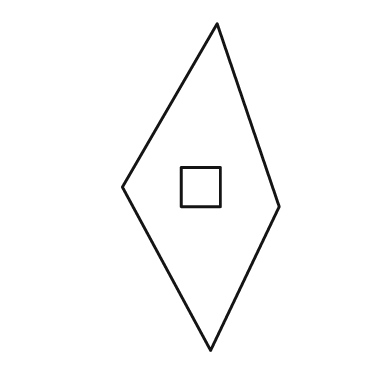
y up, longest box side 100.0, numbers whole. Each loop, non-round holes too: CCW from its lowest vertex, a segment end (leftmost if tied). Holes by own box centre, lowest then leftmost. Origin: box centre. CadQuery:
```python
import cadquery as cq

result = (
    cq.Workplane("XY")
    .moveTo(3.0, -50.0)
    .lineTo(24.0, -6.0)
    .lineTo(5.0, 50.0)
    .lineTo(-24.0, 0.0)
    .close()
    .moveTo(-6.0, -6.0)
    .lineTo(6.0, -6.0)
    .lineTo(6.0, 6.0)
    .lineTo(-6.0, 6.0)
    .close()
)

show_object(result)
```